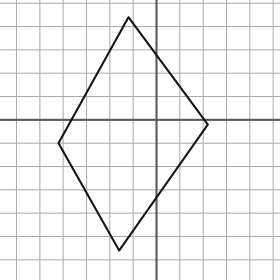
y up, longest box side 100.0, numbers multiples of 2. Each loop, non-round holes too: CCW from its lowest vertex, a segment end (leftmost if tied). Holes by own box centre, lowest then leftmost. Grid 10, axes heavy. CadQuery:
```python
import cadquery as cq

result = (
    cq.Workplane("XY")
    .moveTo(-16.0, -56.0)
    .lineTo(22.0, -2.0)
    .lineTo(-12.0, 44.0)
    .lineTo(-42.0, -10.0)
    .close()
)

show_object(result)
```